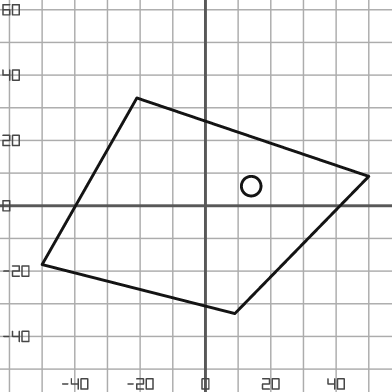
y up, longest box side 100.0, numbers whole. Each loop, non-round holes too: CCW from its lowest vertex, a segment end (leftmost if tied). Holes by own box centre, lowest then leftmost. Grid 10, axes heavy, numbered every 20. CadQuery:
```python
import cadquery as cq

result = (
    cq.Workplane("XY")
    .moveTo(9.0, -33.0)
    .lineTo(50.0, 9.0)
    .lineTo(-21.0, 33.0)
    .lineTo(-50.0, -18.0)
    .close()
    .moveTo(14.0, 6.0)
    .circle(3.0)
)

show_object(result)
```